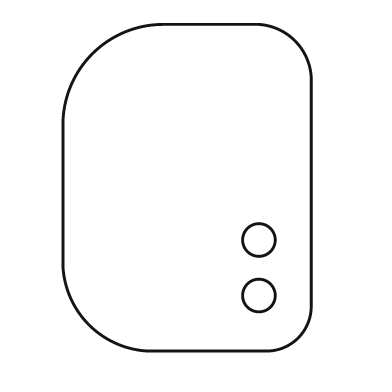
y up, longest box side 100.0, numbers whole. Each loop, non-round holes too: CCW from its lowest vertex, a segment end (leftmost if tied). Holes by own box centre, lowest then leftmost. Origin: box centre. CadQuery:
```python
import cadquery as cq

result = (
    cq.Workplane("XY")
    .moveTo(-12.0, -50.0)
    .lineTo(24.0, -50.0)
    .threePointArc((34.0, -46.0), (38.0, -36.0))
    .lineTo(38.0, 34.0)
    .threePointArc((33.0, 45.0), (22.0, 50.0))
    .lineTo(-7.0, 50.0)
    .threePointArc((-29.0, 41.0), (-38.0, 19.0))
    .lineTo(-38.0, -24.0)
    .threePointArc((-30.0, -42.0), (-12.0, -50.0))
    .close()
    .moveTo(22.0, -33.0)
    .circle(5.0)
    .moveTo(22.0, -16.0)
    .circle(5.0)
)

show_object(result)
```